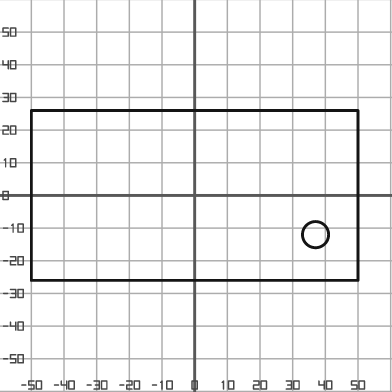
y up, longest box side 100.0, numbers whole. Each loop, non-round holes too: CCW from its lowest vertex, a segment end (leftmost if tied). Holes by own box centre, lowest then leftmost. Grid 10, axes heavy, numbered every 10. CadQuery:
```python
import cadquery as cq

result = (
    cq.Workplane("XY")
    .moveTo(-50.0, -26.0)
    .lineTo(50.0, -26.0)
    .lineTo(50.0, 26.0)
    .lineTo(-50.0, 26.0)
    .close()
    .moveTo(37.0, -12.0)
    .circle(4.0)
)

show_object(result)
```